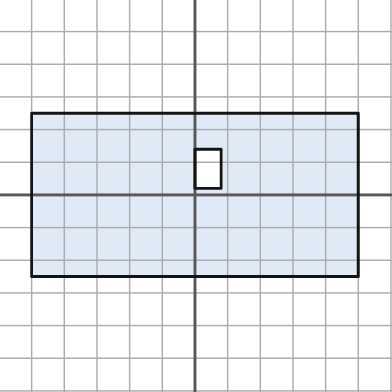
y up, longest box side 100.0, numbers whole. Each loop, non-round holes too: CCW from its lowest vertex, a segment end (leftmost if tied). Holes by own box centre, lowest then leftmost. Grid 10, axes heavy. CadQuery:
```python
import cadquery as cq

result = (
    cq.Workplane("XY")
    .moveTo(-50.0, -25.0)
    .lineTo(50.0, -25.0)
    .lineTo(50.0, 25.0)
    .lineTo(-50.0, 25.0)
    .close()
    .moveTo(0.0, 2.0)
    .lineTo(8.0, 2.0)
    .lineTo(8.0, 14.0)
    .lineTo(0.0, 14.0)
    .close()
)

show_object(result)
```